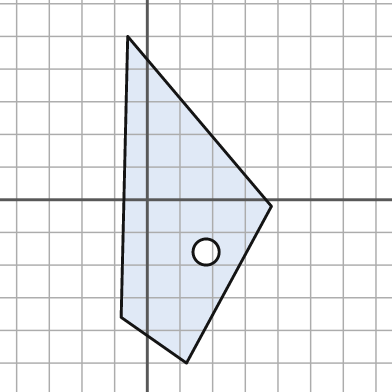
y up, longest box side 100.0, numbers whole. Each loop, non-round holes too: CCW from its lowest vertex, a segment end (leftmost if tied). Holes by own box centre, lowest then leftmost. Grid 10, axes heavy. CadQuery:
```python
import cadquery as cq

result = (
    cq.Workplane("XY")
    .moveTo(12.0, -50.0)
    .lineTo(38.0, -2.0)
    .lineTo(-6.0, 50.0)
    .lineTo(-8.0, -36.0)
    .close()
    .moveTo(18.0, -16.0)
    .circle(4.0)
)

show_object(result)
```